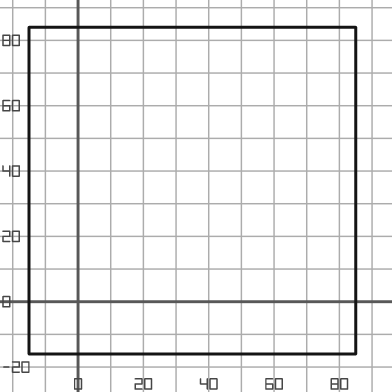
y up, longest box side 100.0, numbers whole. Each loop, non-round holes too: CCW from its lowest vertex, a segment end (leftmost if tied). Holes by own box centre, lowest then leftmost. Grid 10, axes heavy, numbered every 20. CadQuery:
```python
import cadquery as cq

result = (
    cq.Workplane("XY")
    .moveTo(-15.0, -16.0)
    .lineTo(85.0, -16.0)
    .lineTo(85.0, 84.0)
    .lineTo(-15.0, 84.0)
    .close()
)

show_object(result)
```